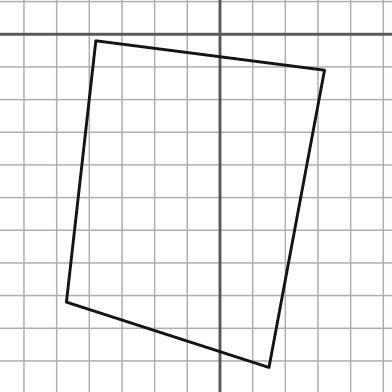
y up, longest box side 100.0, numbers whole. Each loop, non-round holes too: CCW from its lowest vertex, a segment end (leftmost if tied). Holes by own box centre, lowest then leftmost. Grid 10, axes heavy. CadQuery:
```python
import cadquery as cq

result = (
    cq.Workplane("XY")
    .moveTo(15.0, -102.0)
    .lineTo(32.0, -11.0)
    .lineTo(-38.0, -2.0)
    .lineTo(-47.0, -82.0)
    .close()
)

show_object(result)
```